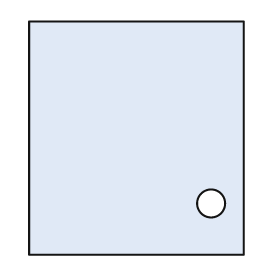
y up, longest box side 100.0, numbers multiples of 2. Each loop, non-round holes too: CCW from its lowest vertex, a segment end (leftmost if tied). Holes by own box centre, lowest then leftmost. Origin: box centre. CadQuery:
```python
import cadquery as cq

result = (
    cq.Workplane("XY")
    .moveTo(-46.0, -50.0)
    .lineTo(46.0, -50.0)
    .lineTo(46.0, 50.0)
    .lineTo(-46.0, 50.0)
    .close()
    .moveTo(32.0, -28.0)
    .circle(6.0)
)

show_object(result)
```